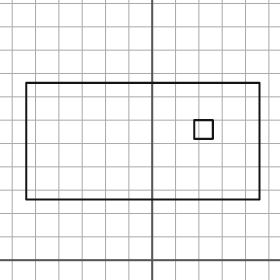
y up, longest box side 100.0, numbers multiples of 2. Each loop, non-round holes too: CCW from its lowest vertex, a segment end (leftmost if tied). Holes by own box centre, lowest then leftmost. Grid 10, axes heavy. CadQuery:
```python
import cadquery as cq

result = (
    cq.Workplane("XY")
    .moveTo(-54.0, 26.0)
    .lineTo(46.0, 26.0)
    .lineTo(46.0, 76.0)
    .lineTo(-54.0, 76.0)
    .close()
    .moveTo(18.0, 52.0)
    .lineTo(26.0, 52.0)
    .lineTo(26.0, 60.0)
    .lineTo(18.0, 60.0)
    .close()
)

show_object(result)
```